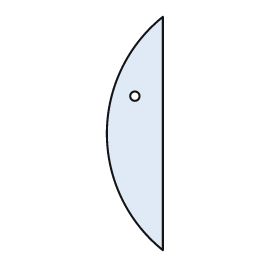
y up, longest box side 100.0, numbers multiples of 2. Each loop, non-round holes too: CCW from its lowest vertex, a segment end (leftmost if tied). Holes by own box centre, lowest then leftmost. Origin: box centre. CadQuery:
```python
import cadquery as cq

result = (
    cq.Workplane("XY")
    .moveTo(12.0, -50.0)
    .lineTo(12.0, 50.0)
    .threePointArc((-12.0, 0.0), (12.0, -50.0))
    .close()
    .moveTo(0.0, 16.0)
    .circle(2.0)
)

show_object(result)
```